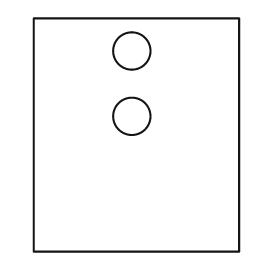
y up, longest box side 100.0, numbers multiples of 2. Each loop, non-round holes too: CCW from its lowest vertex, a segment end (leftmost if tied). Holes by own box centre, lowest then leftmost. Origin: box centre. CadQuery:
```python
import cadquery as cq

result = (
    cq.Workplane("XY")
    .moveTo(-44.0, -50.0)
    .lineTo(44.0, -50.0)
    .lineTo(44.0, 50.0)
    .lineTo(-44.0, 50.0)
    .close()
    .moveTo(-2.0, 8.0)
    .circle(8.0)
    .moveTo(-2.0, 36.0)
    .circle(8.0)
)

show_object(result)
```